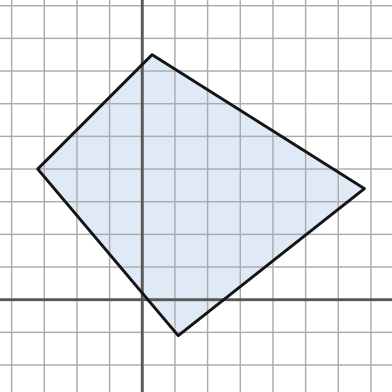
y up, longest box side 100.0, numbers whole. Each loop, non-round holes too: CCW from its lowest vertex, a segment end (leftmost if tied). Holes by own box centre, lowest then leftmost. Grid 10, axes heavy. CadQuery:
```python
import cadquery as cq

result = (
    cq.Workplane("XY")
    .moveTo(11.0, -11.0)
    .lineTo(68.0, 34.0)
    .lineTo(3.0, 75.0)
    .lineTo(-32.0, 40.0)
    .close()
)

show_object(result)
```